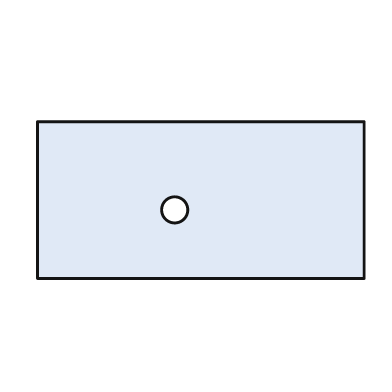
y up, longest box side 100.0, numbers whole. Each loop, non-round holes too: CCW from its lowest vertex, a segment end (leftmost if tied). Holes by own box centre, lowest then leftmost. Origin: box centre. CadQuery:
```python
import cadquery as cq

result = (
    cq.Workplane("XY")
    .moveTo(-50.0, -24.0)
    .lineTo(50.0, -24.0)
    .lineTo(50.0, 24.0)
    .lineTo(-50.0, 24.0)
    .close()
    .moveTo(-8.0, -3.0)
    .circle(4.0)
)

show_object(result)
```